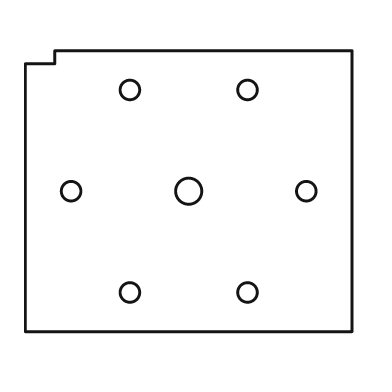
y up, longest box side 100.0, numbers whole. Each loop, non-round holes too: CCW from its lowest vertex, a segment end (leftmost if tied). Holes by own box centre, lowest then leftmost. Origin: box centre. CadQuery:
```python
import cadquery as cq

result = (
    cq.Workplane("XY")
    .moveTo(-50.0, -43.0)
    .lineTo(50.0, -43.0)
    .lineTo(50.0, 43.0)
    .lineTo(-41.0, 43.0)
    .lineTo(-41.0, 39.0)
    .lineTo(-50.0, 39.0)
    .close()
    .moveTo(-18.0, -31.0)
    .circle(3.0)
    .moveTo(18.0, -31.0)
    .circle(3.0)
    .moveTo(-36.0, 0.0)
    .circle(3.0)
    .moveTo(0.0, 0.0)
    .circle(4.0)
    .moveTo(36.0, 0.0)
    .circle(3.0)
    .moveTo(-18.0, 31.0)
    .circle(3.0)
    .moveTo(18.0, 31.0)
    .circle(3.0)
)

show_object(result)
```